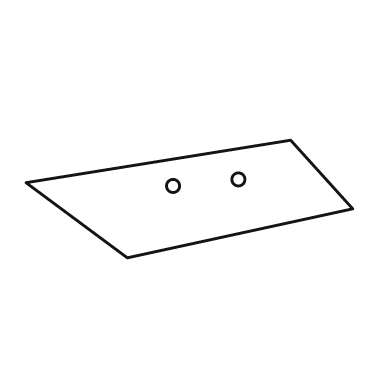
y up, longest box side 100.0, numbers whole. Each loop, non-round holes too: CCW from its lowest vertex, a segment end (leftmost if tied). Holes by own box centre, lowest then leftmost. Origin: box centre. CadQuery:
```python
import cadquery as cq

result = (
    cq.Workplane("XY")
    .moveTo(-19.0, -18.0)
    .lineTo(50.0, -3.0)
    .lineTo(31.0, 18.0)
    .lineTo(-50.0, 5.0)
    .close()
    .moveTo(-5.0, 4.0)
    .circle(2.0)
    .moveTo(15.0, 6.0)
    .circle(2.0)
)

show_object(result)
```